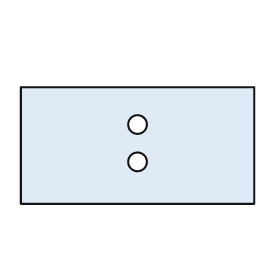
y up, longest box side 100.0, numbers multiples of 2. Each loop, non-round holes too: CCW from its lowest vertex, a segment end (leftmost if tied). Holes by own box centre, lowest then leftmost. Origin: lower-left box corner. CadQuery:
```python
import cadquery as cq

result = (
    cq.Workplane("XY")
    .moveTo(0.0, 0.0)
    .lineTo(100.0, 0.0)
    .lineTo(100.0, 50.0)
    .lineTo(0.0, 50.0)
    .close()
    .moveTo(50.0, 18.0)
    .circle(4.0)
    .moveTo(50.0, 34.0)
    .circle(4.0)
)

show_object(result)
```